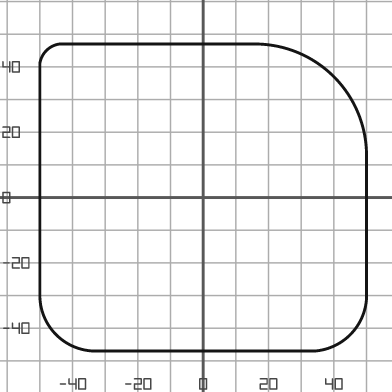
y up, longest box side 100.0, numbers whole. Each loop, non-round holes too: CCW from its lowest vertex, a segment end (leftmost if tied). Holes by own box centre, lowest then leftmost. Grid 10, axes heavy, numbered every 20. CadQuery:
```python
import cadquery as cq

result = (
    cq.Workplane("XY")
    .moveTo(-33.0, -47.0)
    .lineTo(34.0, -47.0)
    .threePointArc((45.0, -42.0), (50.0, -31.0))
    .lineTo(50.0, 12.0)
    .threePointArc((40.0, 37.0), (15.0, 47.0))
    .lineTo(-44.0, 47.0)
    .threePointArc((-48.0, 45.0), (-50.0, 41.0))
    .lineTo(-50.0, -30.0)
    .threePointArc((-45.0, -42.0), (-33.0, -47.0))
    .close()
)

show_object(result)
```